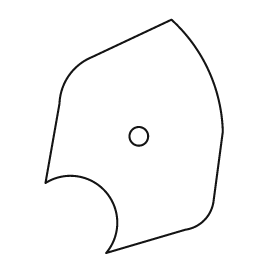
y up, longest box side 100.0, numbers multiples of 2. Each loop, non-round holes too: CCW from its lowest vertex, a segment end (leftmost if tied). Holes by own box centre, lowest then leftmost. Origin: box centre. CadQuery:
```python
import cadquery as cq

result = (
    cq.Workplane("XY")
    .moveTo(-12.0, -50.0)
    .lineTo(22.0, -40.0)
    .threePointArc((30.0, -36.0), (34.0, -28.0))
    .lineTo(38.0, 2.0)
    .threePointArc((32.0, 28.0), (16.0, 50.0))
    .lineTo(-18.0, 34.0)
    .threePointArc((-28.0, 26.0), (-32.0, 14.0))
    .lineTo(-38.0, -20.0)
    .threePointArc((-12.0, -24.0), (-12.0, -50.0))
    .close()
    .moveTo(2.0, 0.0)
    .circle(4.0)
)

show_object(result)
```